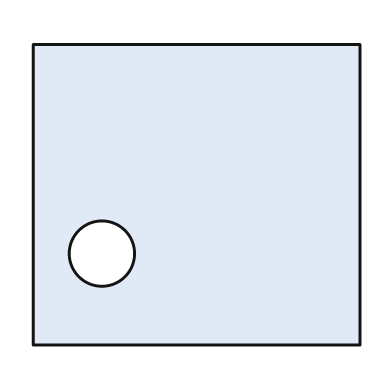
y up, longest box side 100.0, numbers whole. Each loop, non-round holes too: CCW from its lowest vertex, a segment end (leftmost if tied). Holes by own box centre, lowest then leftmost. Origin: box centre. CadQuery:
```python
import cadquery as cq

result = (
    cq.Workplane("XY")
    .moveTo(-50.0, -46.0)
    .lineTo(50.0, -46.0)
    .lineTo(50.0, 46.0)
    .lineTo(-50.0, 46.0)
    .close()
    .moveTo(-29.0, -18.0)
    .circle(10.0)
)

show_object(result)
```